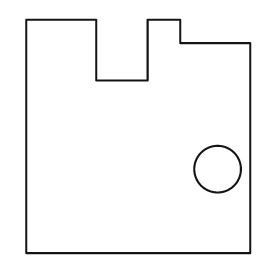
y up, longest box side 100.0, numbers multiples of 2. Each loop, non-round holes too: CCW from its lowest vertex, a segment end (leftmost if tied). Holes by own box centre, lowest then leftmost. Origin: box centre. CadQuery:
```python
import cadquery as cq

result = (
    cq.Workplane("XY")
    .moveTo(-48.0, -50.0)
    .lineTo(48.0, -50.0)
    .lineTo(48.0, 40.0)
    .lineTo(18.0, 40.0)
    .lineTo(18.0, 50.0)
    .lineTo(4.0, 50.0)
    .lineTo(4.0, 24.0)
    .lineTo(-18.0, 24.0)
    .lineTo(-18.0, 50.0)
    .lineTo(-48.0, 50.0)
    .close()
    .moveTo(34.0, -14.0)
    .circle(10.0)
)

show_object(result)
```